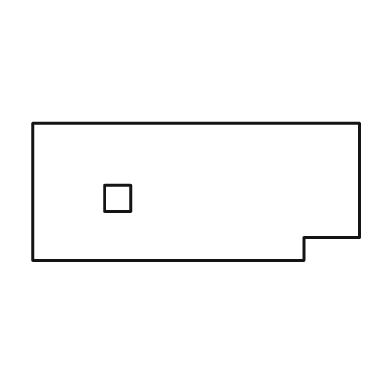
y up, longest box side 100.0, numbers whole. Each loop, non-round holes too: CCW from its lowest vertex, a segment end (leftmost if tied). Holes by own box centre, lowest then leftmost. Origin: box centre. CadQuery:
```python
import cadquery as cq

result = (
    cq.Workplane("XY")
    .moveTo(-50.0, -21.0)
    .lineTo(33.0, -21.0)
    .lineTo(33.0, -14.0)
    .lineTo(50.0, -14.0)
    .lineTo(50.0, 21.0)
    .lineTo(-50.0, 21.0)
    .close()
    .moveTo(-28.0, -6.0)
    .lineTo(-20.0, -6.0)
    .lineTo(-20.0, 2.0)
    .lineTo(-28.0, 2.0)
    .close()
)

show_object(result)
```